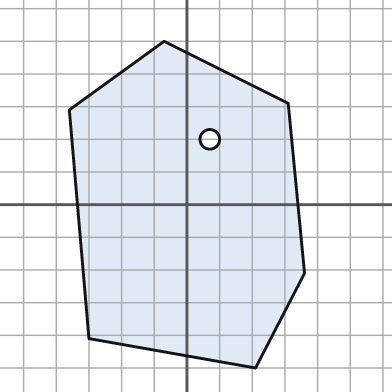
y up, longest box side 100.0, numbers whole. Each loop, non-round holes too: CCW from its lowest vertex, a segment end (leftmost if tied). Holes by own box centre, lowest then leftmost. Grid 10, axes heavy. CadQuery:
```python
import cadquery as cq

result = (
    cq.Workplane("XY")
    .moveTo(21.0, -50.0)
    .lineTo(36.0, -21.0)
    .lineTo(31.0, 31.0)
    .lineTo(-7.0, 50.0)
    .lineTo(-36.0, 29.0)
    .lineTo(-30.0, -41.0)
    .close()
    .moveTo(7.0, 20.0)
    .circle(3.0)
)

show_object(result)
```